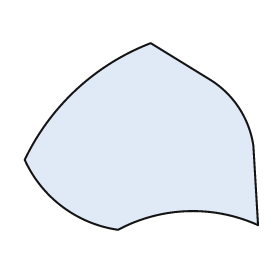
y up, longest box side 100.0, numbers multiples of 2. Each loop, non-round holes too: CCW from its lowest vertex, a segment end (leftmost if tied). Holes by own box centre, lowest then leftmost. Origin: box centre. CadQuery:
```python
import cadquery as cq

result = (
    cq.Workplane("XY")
    .moveTo(-10.0, -40.0)
    .threePointArc((20.0, -32.0), (50.0, -38.0))
    .lineTo(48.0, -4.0)
    .threePointArc((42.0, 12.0), (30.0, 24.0))
    .lineTo(4.0, 40.0)
    .threePointArc((-28.0, 20.0), (-50.0, -10.0))
    .threePointArc((-34.0, -30.0), (-10.0, -40.0))
    .close()
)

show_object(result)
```